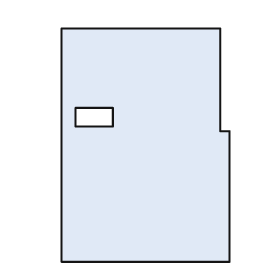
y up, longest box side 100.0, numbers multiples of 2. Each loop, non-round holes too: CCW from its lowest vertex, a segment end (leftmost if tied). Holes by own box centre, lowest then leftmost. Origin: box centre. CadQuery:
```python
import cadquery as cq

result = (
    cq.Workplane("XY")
    .moveTo(-36.0, -50.0)
    .lineTo(36.0, -50.0)
    .lineTo(36.0, 6.0)
    .lineTo(32.0, 6.0)
    .lineTo(32.0, 50.0)
    .lineTo(-36.0, 50.0)
    .close()
    .moveTo(-30.0, 8.0)
    .lineTo(-14.0, 8.0)
    .lineTo(-14.0, 16.0)
    .lineTo(-30.0, 16.0)
    .close()
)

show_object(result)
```